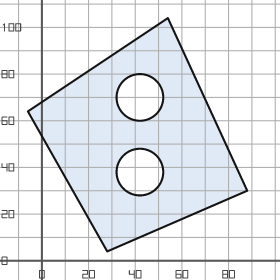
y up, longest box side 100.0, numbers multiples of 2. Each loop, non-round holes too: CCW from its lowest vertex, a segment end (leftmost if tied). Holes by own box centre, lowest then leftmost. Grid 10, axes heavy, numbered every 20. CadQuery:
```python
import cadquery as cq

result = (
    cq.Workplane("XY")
    .moveTo(28.0, 4.0)
    .lineTo(88.0, 30.0)
    .lineTo(54.0, 104.0)
    .lineTo(-6.0, 64.0)
    .close()
    .moveTo(42.0, 38.0)
    .circle(10.0)
    .moveTo(42.0, 70.0)
    .circle(10.0)
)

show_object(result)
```